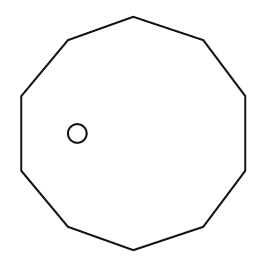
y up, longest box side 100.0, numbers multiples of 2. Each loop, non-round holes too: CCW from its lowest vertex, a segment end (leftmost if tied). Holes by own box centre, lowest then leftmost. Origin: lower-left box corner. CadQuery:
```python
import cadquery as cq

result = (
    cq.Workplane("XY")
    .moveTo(48.0, 0.0)
    .lineTo(78.0, 10.0)
    .lineTo(96.0, 34.0)
    .lineTo(96.0, 66.0)
    .lineTo(78.0, 90.0)
    .lineTo(48.0, 100.0)
    .lineTo(20.0, 90.0)
    .lineTo(0.0, 66.0)
    .lineTo(0.0, 34.0)
    .lineTo(20.0, 10.0)
    .close()
    .moveTo(24.0, 50.0)
    .circle(4.0)
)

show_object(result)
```